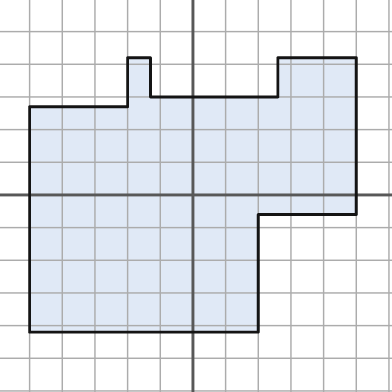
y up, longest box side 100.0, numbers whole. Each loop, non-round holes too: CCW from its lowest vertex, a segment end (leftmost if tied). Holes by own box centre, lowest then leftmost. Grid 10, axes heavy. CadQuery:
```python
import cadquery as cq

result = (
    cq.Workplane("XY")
    .moveTo(-50.0, -42.0)
    .lineTo(20.0, -42.0)
    .lineTo(20.0, -6.0)
    .lineTo(50.0, -6.0)
    .lineTo(50.0, 42.0)
    .lineTo(26.0, 42.0)
    .lineTo(26.0, 30.0)
    .lineTo(-13.0, 30.0)
    .lineTo(-13.0, 42.0)
    .lineTo(-20.0, 42.0)
    .lineTo(-20.0, 27.0)
    .lineTo(-50.0, 27.0)
    .close()
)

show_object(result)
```